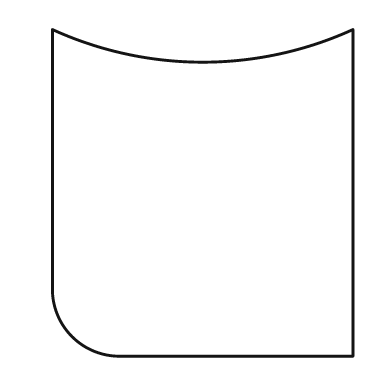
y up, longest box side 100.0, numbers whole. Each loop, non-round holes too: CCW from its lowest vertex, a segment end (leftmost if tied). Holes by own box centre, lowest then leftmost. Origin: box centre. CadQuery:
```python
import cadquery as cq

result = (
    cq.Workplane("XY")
    .moveTo(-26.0, -50.0)
    .lineTo(46.0, -50.0)
    .lineTo(46.0, 50.0)
    .threePointArc((0.0, 40.0), (-46.0, 50.0))
    .lineTo(-46.0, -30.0)
    .threePointArc((-40.0, -44.0), (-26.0, -50.0))
    .close()
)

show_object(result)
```